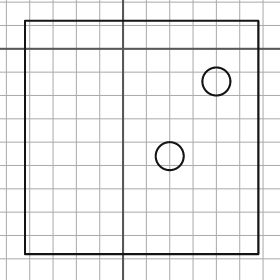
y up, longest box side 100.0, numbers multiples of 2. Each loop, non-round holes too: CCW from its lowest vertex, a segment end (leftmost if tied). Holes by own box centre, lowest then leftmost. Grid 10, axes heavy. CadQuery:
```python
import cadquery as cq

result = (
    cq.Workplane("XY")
    .moveTo(-42.0, -88.0)
    .lineTo(58.0, -88.0)
    .lineTo(58.0, 12.0)
    .lineTo(-42.0, 12.0)
    .close()
    .moveTo(20.0, -46.0)
    .circle(6.0)
    .moveTo(40.0, -14.0)
    .circle(6.0)
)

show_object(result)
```